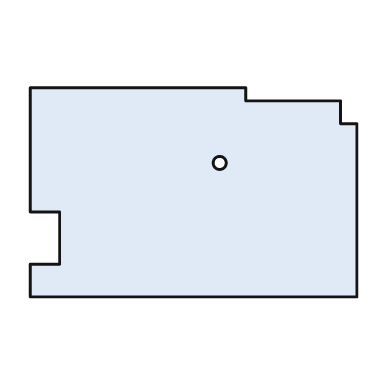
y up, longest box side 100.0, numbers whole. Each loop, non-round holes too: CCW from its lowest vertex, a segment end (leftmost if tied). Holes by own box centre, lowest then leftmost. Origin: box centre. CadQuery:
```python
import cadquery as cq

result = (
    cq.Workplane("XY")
    .moveTo(-50.0, -32.0)
    .lineTo(50.0, -32.0)
    .lineTo(50.0, 21.0)
    .lineTo(45.0, 21.0)
    .lineTo(45.0, 28.0)
    .lineTo(16.0, 28.0)
    .lineTo(16.0, 32.0)
    .lineTo(-50.0, 32.0)
    .lineTo(-50.0, -6.0)
    .lineTo(-41.0, -6.0)
    .lineTo(-41.0, -22.0)
    .lineTo(-50.0, -22.0)
    .close()
    .moveTo(8.0, 9.0)
    .circle(2.0)
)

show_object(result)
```